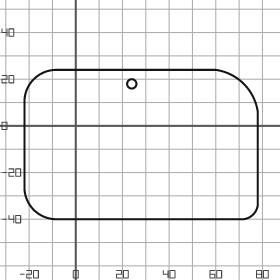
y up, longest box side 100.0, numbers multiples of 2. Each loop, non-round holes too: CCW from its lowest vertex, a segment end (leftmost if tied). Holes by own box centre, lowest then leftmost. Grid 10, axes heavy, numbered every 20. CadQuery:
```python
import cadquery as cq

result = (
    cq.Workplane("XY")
    .moveTo(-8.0, -40.0)
    .lineTo(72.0, -40.0)
    .threePointArc((76.0, -38.0), (78.0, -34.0))
    .lineTo(78.0, 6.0)
    .threePointArc((72.0, 18.0), (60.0, 24.0))
    .lineTo(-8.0, 24.0)
    .threePointArc((-18.0, 20.0), (-22.0, 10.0))
    .lineTo(-22.0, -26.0)
    .threePointArc((-18.0, -36.0), (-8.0, -40.0))
    .close()
    .moveTo(24.0, 18.0)
    .circle(2.0)
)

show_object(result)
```